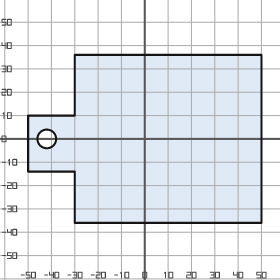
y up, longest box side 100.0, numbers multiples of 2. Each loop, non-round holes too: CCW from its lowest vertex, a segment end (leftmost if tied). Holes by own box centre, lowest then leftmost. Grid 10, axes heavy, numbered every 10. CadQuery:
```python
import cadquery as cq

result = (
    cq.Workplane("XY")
    .moveTo(-30.0, -36.0)
    .lineTo(50.0, -36.0)
    .lineTo(50.0, 36.0)
    .lineTo(-30.0, 36.0)
    .lineTo(-30.0, 10.0)
    .lineTo(-50.0, 10.0)
    .lineTo(-50.0, -14.0)
    .lineTo(-30.0, -14.0)
    .close()
    .moveTo(-42.0, 0.0)
    .circle(4.0)
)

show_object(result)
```